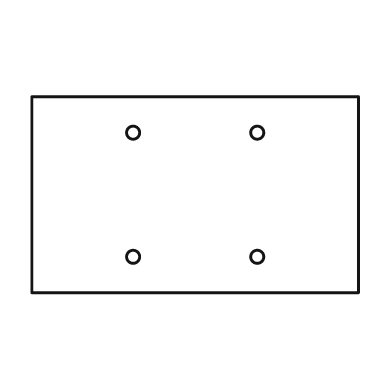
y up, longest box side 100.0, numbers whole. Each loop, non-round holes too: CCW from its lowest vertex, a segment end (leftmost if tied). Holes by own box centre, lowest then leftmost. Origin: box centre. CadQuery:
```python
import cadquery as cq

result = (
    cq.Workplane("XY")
    .moveTo(-50.0, -30.0)
    .lineTo(50.0, -30.0)
    .lineTo(50.0, 30.0)
    .lineTo(-50.0, 30.0)
    .close()
    .moveTo(-19.0, -19.0)
    .circle(2.0)
    .moveTo(19.0, -19.0)
    .circle(2.0)
    .moveTo(-19.0, 19.0)
    .circle(2.0)
    .moveTo(19.0, 19.0)
    .circle(2.0)
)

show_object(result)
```